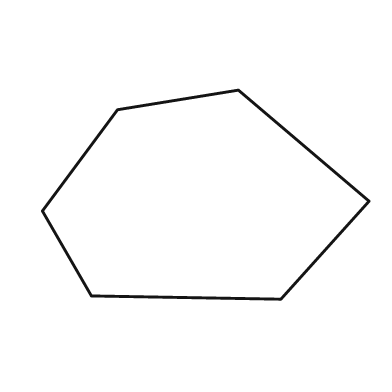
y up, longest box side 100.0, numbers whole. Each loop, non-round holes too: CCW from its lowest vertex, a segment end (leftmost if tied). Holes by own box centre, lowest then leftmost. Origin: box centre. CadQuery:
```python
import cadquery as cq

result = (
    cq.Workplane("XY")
    .moveTo(23.0, -32.0)
    .lineTo(50.0, -2.0)
    .lineTo(10.0, 32.0)
    .lineTo(-27.0, 26.0)
    .lineTo(-50.0, -5.0)
    .lineTo(-35.0, -31.0)
    .close()
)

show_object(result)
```